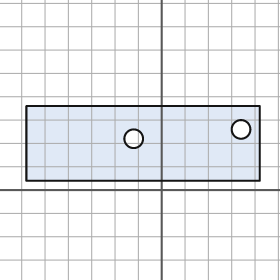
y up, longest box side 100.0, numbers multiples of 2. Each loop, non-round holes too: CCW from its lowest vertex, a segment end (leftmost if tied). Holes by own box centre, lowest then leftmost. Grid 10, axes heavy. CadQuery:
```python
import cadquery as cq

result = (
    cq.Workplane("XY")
    .moveTo(-58.0, 4.0)
    .lineTo(42.0, 4.0)
    .lineTo(42.0, 36.0)
    .lineTo(-58.0, 36.0)
    .close()
    .moveTo(-12.0, 22.0)
    .circle(4.0)
    .moveTo(34.0, 26.0)
    .circle(4.0)
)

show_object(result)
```